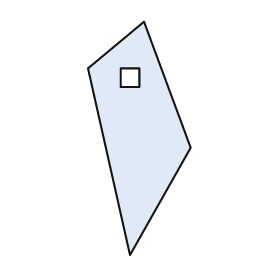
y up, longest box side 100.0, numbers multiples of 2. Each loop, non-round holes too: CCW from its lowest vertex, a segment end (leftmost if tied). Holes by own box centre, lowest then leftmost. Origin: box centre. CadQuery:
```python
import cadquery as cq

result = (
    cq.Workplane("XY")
    .moveTo(-4.0, -50.0)
    .lineTo(22.0, -4.0)
    .lineTo(2.0, 50.0)
    .lineTo(-22.0, 30.0)
    .close()
    .moveTo(-8.0, 22.0)
    .lineTo(0.0, 22.0)
    .lineTo(0.0, 30.0)
    .lineTo(-8.0, 30.0)
    .close()
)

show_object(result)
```